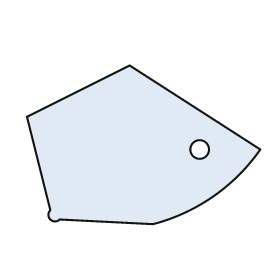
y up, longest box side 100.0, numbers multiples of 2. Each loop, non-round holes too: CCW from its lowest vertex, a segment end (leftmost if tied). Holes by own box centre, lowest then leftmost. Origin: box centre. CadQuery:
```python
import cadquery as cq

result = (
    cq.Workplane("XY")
    .moveTo(4.0, -34.0)
    .threePointArc((30.0, -22.0), (50.0, -2.0))
    .lineTo(-6.0, 34.0)
    .lineTo(-50.0, 12.0)
    .lineTo(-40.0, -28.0)
    .threePointArc((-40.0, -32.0), (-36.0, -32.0))
    .close()
    .moveTo(24.0, -2.0)
    .circle(4.0)
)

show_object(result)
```